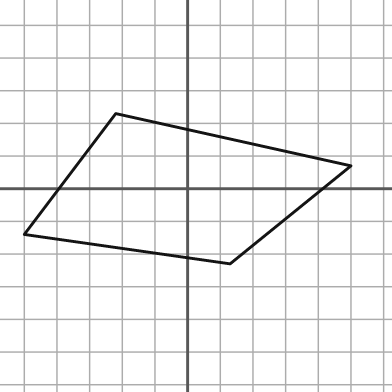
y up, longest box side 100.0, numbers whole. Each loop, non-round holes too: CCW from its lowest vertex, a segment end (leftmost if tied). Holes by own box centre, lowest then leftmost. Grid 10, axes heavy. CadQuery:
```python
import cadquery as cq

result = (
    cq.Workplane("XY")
    .moveTo(13.0, -23.0)
    .lineTo(50.0, 7.0)
    .lineTo(-22.0, 23.0)
    .lineTo(-50.0, -14.0)
    .close()
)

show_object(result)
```